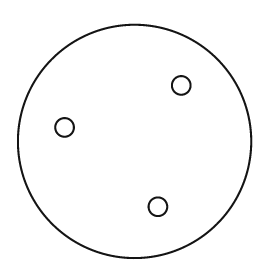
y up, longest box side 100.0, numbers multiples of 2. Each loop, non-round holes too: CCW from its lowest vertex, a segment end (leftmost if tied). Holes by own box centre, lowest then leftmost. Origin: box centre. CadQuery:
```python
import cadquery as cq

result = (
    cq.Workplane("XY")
    .moveTo(0.0, 0.0)
    .circle(50.0)
    .moveTo(10.0, -28.0)
    .circle(4.0)
    .moveTo(-30.0, 6.0)
    .circle(4.0)
    .moveTo(20.0, 24.0)
    .circle(4.0)
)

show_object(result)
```